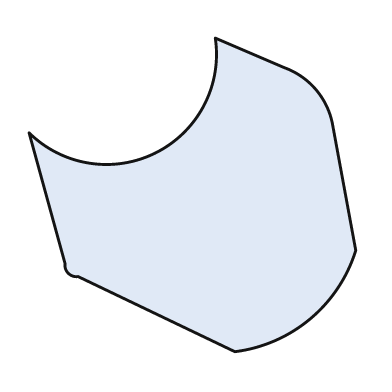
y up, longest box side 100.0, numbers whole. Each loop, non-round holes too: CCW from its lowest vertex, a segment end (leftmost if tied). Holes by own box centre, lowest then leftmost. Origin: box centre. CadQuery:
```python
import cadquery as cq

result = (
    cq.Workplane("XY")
    .moveTo(13.0, -48.0)
    .threePointArc((36.0, -38.0), (50.0, -17.0))
    .lineTo(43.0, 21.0)
    .threePointArc((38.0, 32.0), (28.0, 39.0))
    .lineTo(7.0, 48.0)
    .threePointArc((-11.0, 13.0), (-50.0, 19.0))
    .lineTo(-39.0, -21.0)
    .threePointArc((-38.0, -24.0), (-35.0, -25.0))
    .close()
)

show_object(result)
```